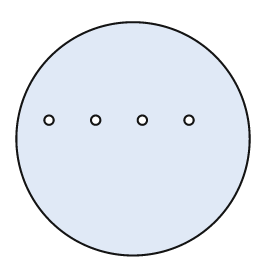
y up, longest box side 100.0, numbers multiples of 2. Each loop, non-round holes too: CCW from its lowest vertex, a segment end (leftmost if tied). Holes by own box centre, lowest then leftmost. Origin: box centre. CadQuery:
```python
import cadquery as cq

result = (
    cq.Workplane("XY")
    .moveTo(0.0, 0.0)
    .circle(50.0)
    .moveTo(-36.0, 8.0)
    .circle(2.0)
    .moveTo(-16.0, 8.0)
    .circle(2.0)
    .moveTo(4.0, 8.0)
    .circle(2.0)
    .moveTo(24.0, 8.0)
    .circle(2.0)
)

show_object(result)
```